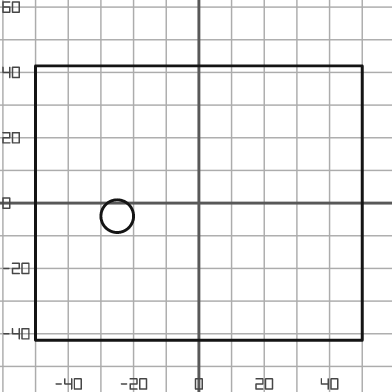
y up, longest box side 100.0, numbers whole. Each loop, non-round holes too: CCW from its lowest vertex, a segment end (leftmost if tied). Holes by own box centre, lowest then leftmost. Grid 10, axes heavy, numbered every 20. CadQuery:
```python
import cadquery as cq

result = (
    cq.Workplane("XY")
    .moveTo(-50.0, -42.0)
    .lineTo(50.0, -42.0)
    .lineTo(50.0, 42.0)
    .lineTo(-50.0, 42.0)
    .close()
    .moveTo(-25.0, -4.0)
    .circle(5.0)
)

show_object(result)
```